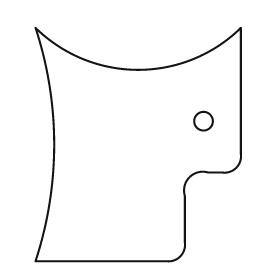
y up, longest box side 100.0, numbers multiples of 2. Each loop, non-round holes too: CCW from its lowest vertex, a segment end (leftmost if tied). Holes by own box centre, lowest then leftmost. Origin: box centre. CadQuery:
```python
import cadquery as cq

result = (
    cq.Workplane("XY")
    .moveTo(-44.0, -50.0)
    .lineTo(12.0, -50.0)
    .threePointArc((18.0, -48.0), (20.0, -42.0))
    .lineTo(20.0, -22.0)
    .threePointArc((22.0, -14.0), (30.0, -12.0))
    .lineTo(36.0, -12.0)
    .threePointArc((42.0, -10.0), (44.0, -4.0))
    .lineTo(44.0, 50.0)
    .threePointArc((0.0, 32.0), (-44.0, 50.0))
    .threePointArc((-36.0, 0.0), (-44.0, -50.0))
    .close()
    .moveTo(28.0, 10.0)
    .circle(4.0)
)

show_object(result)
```